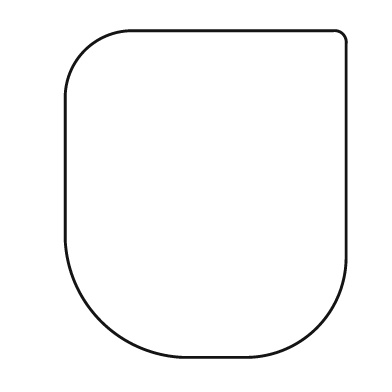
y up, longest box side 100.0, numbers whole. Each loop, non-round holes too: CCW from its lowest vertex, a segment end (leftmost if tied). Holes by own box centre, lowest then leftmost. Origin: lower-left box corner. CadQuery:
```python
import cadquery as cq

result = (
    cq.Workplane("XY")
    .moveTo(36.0, 0.0)
    .lineTo(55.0, 0.0)
    .threePointArc((77.0, 9.0), (86.0, 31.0))
    .lineTo(86.0, 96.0)
    .threePointArc((85.0, 99.0), (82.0, 100.0))
    .lineTo(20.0, 100.0)
    .threePointArc((6.0, 94.0), (0.0, 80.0))
    .lineTo(0.0, 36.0)
    .threePointArc((11.0, 11.0), (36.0, 0.0))
    .close()
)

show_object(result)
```